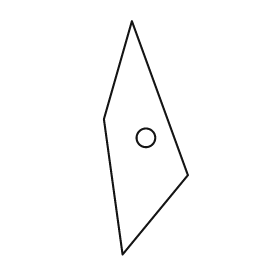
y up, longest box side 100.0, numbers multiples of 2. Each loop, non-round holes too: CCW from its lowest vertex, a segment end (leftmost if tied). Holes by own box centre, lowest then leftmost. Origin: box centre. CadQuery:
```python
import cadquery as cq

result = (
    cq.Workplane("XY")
    .moveTo(-10.0, -50.0)
    .lineTo(18.0, -16.0)
    .lineTo(-6.0, 50.0)
    .lineTo(-18.0, 8.0)
    .close()
    .moveTo(0.0, 0.0)
    .circle(4.0)
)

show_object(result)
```